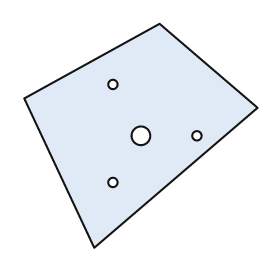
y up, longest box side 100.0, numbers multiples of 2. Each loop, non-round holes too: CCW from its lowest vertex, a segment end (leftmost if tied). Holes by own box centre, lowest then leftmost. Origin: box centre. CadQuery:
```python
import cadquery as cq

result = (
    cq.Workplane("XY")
    .moveTo(-20.0, -48.0)
    .lineTo(50.0, 12.0)
    .lineTo(8.0, 48.0)
    .lineTo(-50.0, 16.0)
    .close()
    .moveTo(-12.0, -20.0)
    .circle(2.0)
    .moveTo(0.0, 0.0)
    .circle(4.0)
    .moveTo(24.0, 0.0)
    .circle(2.0)
    .moveTo(-12.0, 22.0)
    .circle(2.0)
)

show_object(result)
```